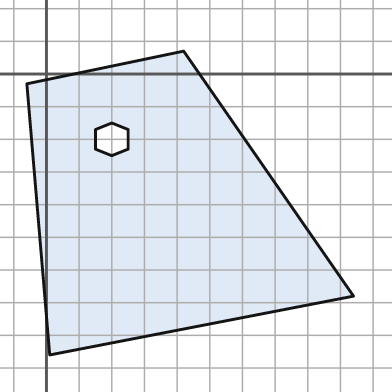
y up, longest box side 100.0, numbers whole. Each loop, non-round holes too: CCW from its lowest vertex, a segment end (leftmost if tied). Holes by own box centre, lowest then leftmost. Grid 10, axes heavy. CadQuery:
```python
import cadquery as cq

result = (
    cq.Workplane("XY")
    .moveTo(1.0, -86.0)
    .lineTo(94.0, -68.0)
    .lineTo(42.0, 7.0)
    .lineTo(-6.0, -3.0)
    .close()
    .moveTo(20.0, -25.0)
    .lineTo(25.0, -23.0)
    .lineTo(25.0, -17.0)
    .lineTo(20.0, -15.0)
    .lineTo(15.0, -17.0)
    .lineTo(15.0, -23.0)
    .close()
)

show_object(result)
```